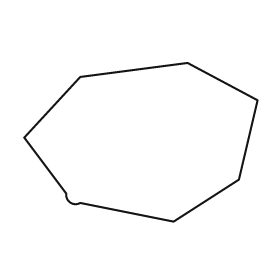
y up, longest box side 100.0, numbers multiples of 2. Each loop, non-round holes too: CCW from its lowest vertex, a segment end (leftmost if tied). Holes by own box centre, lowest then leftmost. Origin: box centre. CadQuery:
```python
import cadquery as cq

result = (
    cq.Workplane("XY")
    .moveTo(14.0, -34.0)
    .lineTo(42.0, -16.0)
    .lineTo(50.0, 18.0)
    .lineTo(20.0, 34.0)
    .lineTo(-26.0, 28.0)
    .lineTo(-50.0, 2.0)
    .lineTo(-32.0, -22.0)
    .threePointArc((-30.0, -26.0), (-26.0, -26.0))
    .close()
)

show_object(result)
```